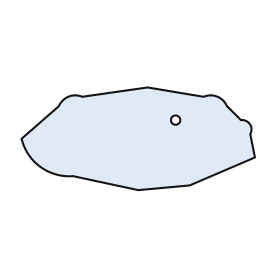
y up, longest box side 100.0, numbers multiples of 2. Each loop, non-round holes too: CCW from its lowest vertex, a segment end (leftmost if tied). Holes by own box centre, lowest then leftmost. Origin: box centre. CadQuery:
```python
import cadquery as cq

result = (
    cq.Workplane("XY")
    .moveTo(0.0, -22.0)
    .lineTo(22.0, -20.0)
    .lineTo(50.0, -8.0)
    .lineTo(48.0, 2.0)
    .threePointArc((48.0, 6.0), (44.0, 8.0))
    .lineTo(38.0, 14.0)
    .threePointArc((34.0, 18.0), (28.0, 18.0))
    .lineTo(4.0, 22.0)
    .lineTo(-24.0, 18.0)
    .threePointArc((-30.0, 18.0), (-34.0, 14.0))
    .lineTo(-50.0, 0.0)
    .threePointArc((-42.0, -12.0), (-28.0, -16.0))
    .close()
    .moveTo(16.0, 8.0)
    .circle(2.0)
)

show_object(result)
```